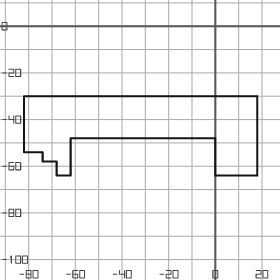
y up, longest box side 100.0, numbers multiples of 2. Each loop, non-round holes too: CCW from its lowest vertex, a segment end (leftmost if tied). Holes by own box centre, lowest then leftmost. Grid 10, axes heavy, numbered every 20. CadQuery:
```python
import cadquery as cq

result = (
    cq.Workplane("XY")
    .moveTo(-68.0, -64.0)
    .lineTo(-62.0, -64.0)
    .lineTo(-62.0, -48.0)
    .lineTo(0.0, -48.0)
    .lineTo(0.0, -64.0)
    .lineTo(18.0, -64.0)
    .lineTo(18.0, -30.0)
    .lineTo(-82.0, -30.0)
    .lineTo(-82.0, -54.0)
    .lineTo(-74.0, -54.0)
    .lineTo(-74.0, -58.0)
    .lineTo(-68.0, -58.0)
    .close()
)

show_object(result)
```